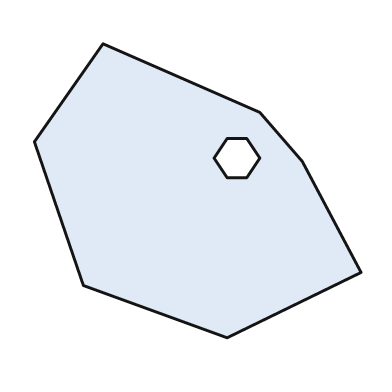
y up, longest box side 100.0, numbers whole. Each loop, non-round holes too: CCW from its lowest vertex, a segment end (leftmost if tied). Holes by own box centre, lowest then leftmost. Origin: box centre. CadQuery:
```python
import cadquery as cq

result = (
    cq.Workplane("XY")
    .moveTo(9.0, -45.0)
    .lineTo(50.0, -25.0)
    .lineTo(32.0, 9.0)
    .lineTo(19.0, 24.0)
    .lineTo(-29.0, 45.0)
    .lineTo(-50.0, 15.0)
    .lineTo(-35.0, -29.0)
    .close()
    .moveTo(9.0, 4.0)
    .lineTo(15.0, 4.0)
    .lineTo(19.0, 10.0)
    .lineTo(15.0, 16.0)
    .lineTo(9.0, 16.0)
    .lineTo(5.0, 10.0)
    .close()
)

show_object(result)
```